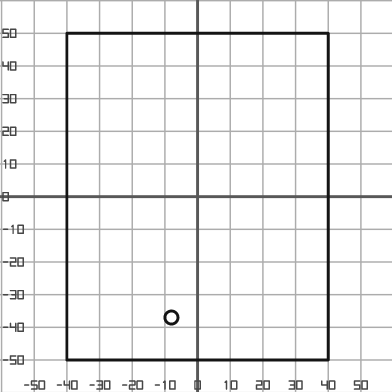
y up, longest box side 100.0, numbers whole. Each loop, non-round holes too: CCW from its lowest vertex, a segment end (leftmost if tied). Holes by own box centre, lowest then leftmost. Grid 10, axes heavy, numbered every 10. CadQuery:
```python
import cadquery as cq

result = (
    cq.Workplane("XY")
    .moveTo(-40.0, -50.0)
    .lineTo(40.0, -50.0)
    .lineTo(40.0, 50.0)
    .lineTo(-40.0, 50.0)
    .close()
    .moveTo(-8.0, -37.0)
    .circle(2.0)
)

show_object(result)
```